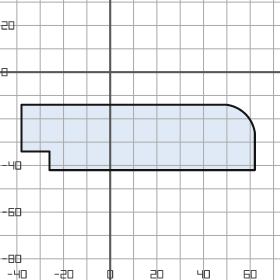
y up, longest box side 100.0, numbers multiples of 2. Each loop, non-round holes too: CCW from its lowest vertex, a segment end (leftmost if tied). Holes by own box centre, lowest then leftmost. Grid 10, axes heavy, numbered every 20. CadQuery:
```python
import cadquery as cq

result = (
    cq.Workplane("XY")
    .moveTo(-26.0, -42.0)
    .lineTo(62.0, -42.0)
    .lineTo(62.0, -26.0)
    .threePointArc((58.0, -18.0), (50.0, -14.0))
    .lineTo(-38.0, -14.0)
    .lineTo(-38.0, -34.0)
    .lineTo(-26.0, -34.0)
    .close()
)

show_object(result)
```